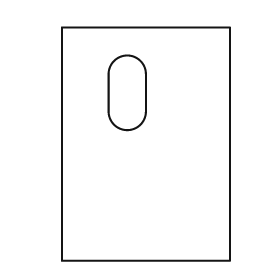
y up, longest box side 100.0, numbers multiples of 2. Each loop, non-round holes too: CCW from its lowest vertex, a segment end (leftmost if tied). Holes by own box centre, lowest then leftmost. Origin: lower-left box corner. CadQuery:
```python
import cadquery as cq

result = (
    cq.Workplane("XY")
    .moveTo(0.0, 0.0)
    .lineTo(72.0, 0.0)
    .lineTo(72.0, 100.0)
    .lineTo(0.0, 100.0)
    .close()
    .moveTo(20.0, 64.0)
    .threePointArc((28.0, 56.0), (36.0, 64.0))
    .lineTo(36.0, 80.0)
    .threePointArc((28.0, 88.0), (20.0, 80.0))
    .close()
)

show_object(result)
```